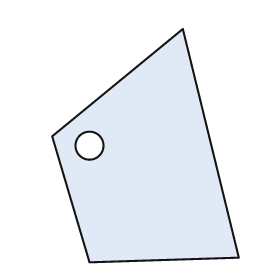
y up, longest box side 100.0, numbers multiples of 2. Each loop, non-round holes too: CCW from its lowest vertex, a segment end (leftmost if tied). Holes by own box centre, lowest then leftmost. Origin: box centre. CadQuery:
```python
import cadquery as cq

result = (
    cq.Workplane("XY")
    .moveTo(-24.0, -50.0)
    .lineTo(40.0, -48.0)
    .lineTo(16.0, 50.0)
    .lineTo(-40.0, 4.0)
    .close()
    .moveTo(-24.0, 0.0)
    .circle(6.0)
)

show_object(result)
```